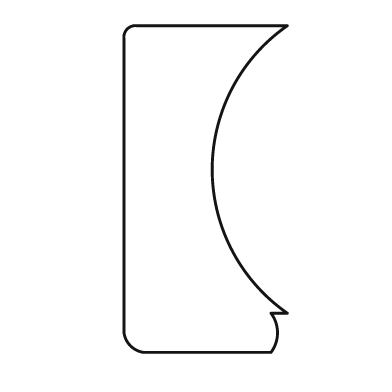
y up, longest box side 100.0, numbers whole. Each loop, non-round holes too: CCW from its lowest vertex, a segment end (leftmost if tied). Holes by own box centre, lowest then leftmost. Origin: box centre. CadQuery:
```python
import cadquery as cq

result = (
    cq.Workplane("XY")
    .moveTo(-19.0, -50.0)
    .lineTo(20.0, -50.0)
    .threePointArc((22.0, -44.0), (20.0, -38.0))
    .lineTo(25.0, -38.0)
    .threePointArc((2.0, 6.0), (25.0, 50.0))
    .lineTo(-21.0, 50.0)
    .threePointArc((-24.0, 49.0), (-25.0, 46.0))
    .lineTo(-25.0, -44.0)
    .threePointArc((-23.0, -48.0), (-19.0, -50.0))
    .close()
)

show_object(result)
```